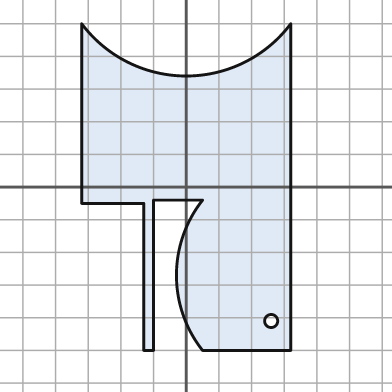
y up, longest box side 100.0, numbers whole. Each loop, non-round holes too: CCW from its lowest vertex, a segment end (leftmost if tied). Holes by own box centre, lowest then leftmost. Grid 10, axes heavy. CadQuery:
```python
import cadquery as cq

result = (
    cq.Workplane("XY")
    .moveTo(-13.0, -50.0)
    .lineTo(-10.0, -50.0)
    .lineTo(-10.0, -4.0)
    .lineTo(5.0, -4.0)
    .threePointArc((-3.0, -27.0), (5.0, -50.0))
    .lineTo(32.0, -50.0)
    .lineTo(32.0, 50.0)
    .threePointArc((0.0, 34.0), (-32.0, 50.0))
    .lineTo(-32.0, -5.0)
    .lineTo(-13.0, -5.0)
    .close()
    .moveTo(26.0, -41.0)
    .circle(2.0)
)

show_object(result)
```